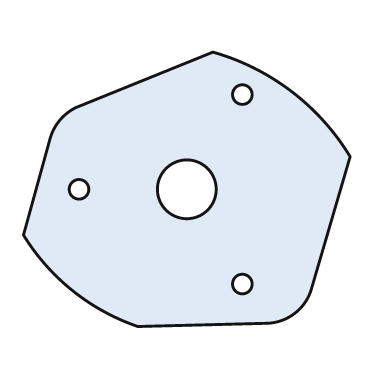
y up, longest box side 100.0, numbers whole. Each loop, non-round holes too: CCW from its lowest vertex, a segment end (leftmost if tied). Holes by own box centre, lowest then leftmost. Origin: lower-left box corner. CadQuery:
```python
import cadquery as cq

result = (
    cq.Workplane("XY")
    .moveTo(35.0, 0.0)
    .lineTo(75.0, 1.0)
    .threePointArc((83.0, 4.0), (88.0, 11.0))
    .lineTo(100.0, 52.0)
    .threePointArc((82.0, 72.0), (58.0, 84.0))
    .lineTo(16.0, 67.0)
    .threePointArc((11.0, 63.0), (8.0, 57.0))
    .lineTo(0.0, 28.0)
    .threePointArc((15.0, 11.0), (35.0, 0.0))
    .close()
    .moveTo(67.0, 13.0)
    .circle(3.0)
    .moveTo(17.0, 42.0)
    .circle(3.0)
    .moveTo(50.0, 42.0)
    .circle(9.0)
    .moveTo(67.0, 71.0)
    .circle(3.0)
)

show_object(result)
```